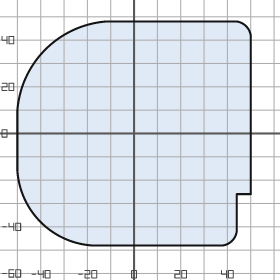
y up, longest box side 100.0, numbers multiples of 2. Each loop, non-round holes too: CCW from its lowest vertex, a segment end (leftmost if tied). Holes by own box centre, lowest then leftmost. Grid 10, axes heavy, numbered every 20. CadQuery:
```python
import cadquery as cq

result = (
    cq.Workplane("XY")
    .moveTo(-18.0, -48.0)
    .lineTo(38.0, -48.0)
    .threePointArc((42.0, -46.0), (44.0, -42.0))
    .lineTo(44.0, -26.0)
    .lineTo(50.0, -26.0)
    .lineTo(50.0, 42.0)
    .threePointArc((48.0, 46.0), (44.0, 48.0))
    .lineTo(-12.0, 48.0)
    .threePointArc((-38.0, 36.0), (-50.0, 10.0))
    .lineTo(-50.0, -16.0)
    .threePointArc((-40.0, -38.0), (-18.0, -48.0))
    .close()
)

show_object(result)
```